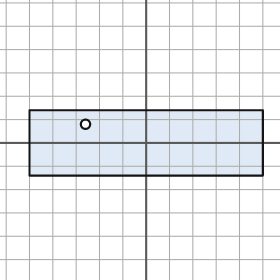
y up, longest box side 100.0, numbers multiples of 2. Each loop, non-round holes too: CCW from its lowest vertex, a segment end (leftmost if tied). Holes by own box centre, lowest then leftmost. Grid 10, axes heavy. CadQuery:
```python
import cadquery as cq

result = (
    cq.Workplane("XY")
    .moveTo(-50.0, -14.0)
    .lineTo(50.0, -14.0)
    .lineTo(50.0, 14.0)
    .lineTo(-50.0, 14.0)
    .close()
    .moveTo(-26.0, 8.0)
    .circle(2.0)
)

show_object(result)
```